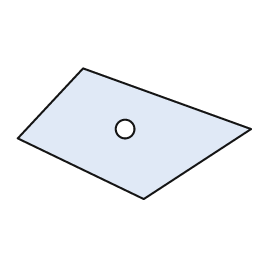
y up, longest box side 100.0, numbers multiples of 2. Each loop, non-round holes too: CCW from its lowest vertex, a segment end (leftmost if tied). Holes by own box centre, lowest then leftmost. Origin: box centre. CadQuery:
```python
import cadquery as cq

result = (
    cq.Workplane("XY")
    .moveTo(4.0, -28.0)
    .lineTo(50.0, 2.0)
    .lineTo(-22.0, 28.0)
    .lineTo(-50.0, -2.0)
    .close()
    .moveTo(-4.0, 2.0)
    .circle(4.0)
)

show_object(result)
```